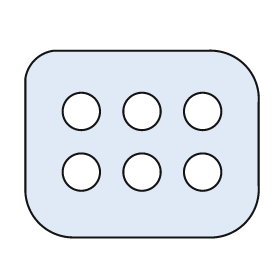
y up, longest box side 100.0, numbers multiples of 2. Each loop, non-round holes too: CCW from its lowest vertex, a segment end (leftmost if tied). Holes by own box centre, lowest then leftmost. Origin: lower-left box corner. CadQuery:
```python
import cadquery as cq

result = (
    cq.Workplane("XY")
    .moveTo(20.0, 0.0)
    .lineTo(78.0, 0.0)
    .threePointArc((94.0, 6.0), (100.0, 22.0))
    .lineTo(100.0, 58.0)
    .threePointArc((94.0, 74.0), (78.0, 80.0))
    .lineTo(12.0, 80.0)
    .threePointArc((4.0, 76.0), (0.0, 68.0))
    .lineTo(0.0, 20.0)
    .threePointArc((6.0, 6.0), (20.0, 0.0))
    .close()
    .moveTo(24.0, 28.0)
    .circle(8.0)
    .moveTo(50.0, 28.0)
    .circle(8.0)
    .moveTo(76.0, 28.0)
    .circle(8.0)
    .moveTo(24.0, 54.0)
    .circle(8.0)
    .moveTo(50.0, 54.0)
    .circle(8.0)
    .moveTo(76.0, 54.0)
    .circle(8.0)
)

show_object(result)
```